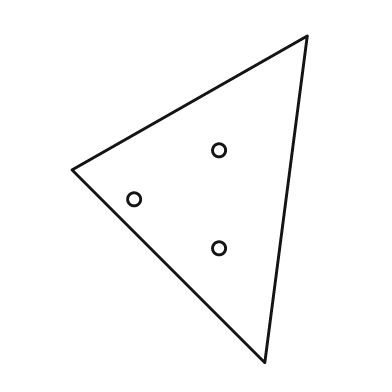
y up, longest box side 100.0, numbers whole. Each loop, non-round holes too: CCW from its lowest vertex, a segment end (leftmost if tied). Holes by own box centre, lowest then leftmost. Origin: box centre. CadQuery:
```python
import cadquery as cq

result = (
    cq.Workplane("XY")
    .moveTo(23.0, -50.0)
    .lineTo(36.0, 50.0)
    .lineTo(-36.0, 9.0)
    .close()
    .moveTo(9.0, -15.0)
    .circle(2.0)
    .moveTo(-17.0, 0.0)
    .circle(2.0)
    .moveTo(9.0, 15.0)
    .circle(2.0)
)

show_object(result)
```